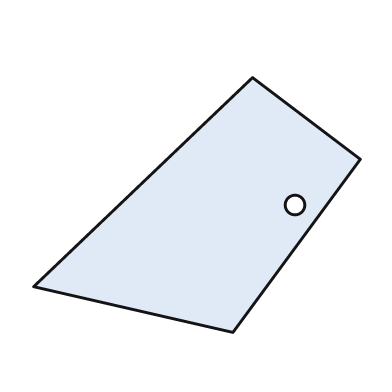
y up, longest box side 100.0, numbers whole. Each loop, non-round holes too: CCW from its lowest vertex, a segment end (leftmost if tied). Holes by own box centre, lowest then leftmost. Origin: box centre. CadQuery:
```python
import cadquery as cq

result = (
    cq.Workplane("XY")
    .moveTo(11.0, -39.0)
    .lineTo(50.0, 14.0)
    .lineTo(17.0, 39.0)
    .lineTo(-50.0, -25.0)
    .close()
    .moveTo(30.0, 0.0)
    .circle(3.0)
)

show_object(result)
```